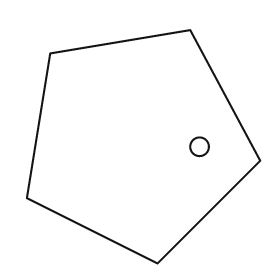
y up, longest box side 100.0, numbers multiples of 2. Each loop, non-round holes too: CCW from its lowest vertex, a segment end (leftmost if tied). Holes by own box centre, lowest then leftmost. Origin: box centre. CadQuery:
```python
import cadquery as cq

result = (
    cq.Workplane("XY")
    .moveTo(6.0, -50.0)
    .lineTo(50.0, -6.0)
    .lineTo(20.0, 50.0)
    .lineTo(-40.0, 40.0)
    .lineTo(-50.0, -22.0)
    .close()
    .moveTo(24.0, 0.0)
    .circle(4.0)
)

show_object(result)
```